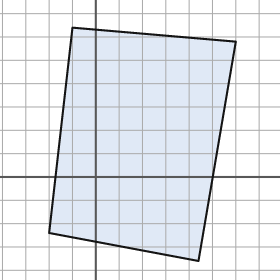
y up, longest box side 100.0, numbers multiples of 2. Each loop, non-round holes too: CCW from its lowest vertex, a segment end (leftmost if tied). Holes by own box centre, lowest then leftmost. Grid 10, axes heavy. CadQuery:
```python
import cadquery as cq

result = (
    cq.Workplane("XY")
    .moveTo(44.0, -36.0)
    .lineTo(60.0, 58.0)
    .lineTo(-10.0, 64.0)
    .lineTo(-20.0, -24.0)
    .close()
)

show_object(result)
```